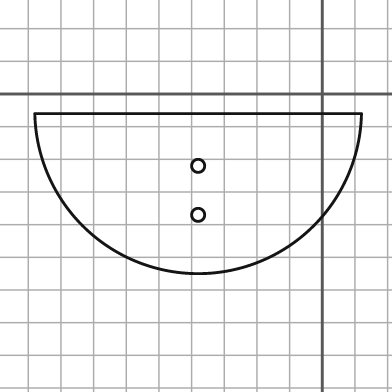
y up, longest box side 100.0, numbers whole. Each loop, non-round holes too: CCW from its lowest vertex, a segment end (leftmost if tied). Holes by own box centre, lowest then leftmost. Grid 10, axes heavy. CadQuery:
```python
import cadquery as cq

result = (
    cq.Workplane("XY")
    .moveTo(-88.0, -6.0)
    .threePointArc((-38.0, -55.0), (12.0, -6.0))
    .close()
    .moveTo(-38.0, -37.0)
    .circle(2.0)
    .moveTo(-38.0, -22.0)
    .circle(2.0)
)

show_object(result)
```